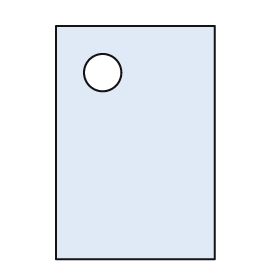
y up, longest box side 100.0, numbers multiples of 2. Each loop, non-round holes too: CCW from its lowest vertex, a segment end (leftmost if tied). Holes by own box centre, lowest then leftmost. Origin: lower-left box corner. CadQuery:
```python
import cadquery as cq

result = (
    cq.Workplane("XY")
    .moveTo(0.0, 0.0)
    .lineTo(68.0, 0.0)
    .lineTo(68.0, 100.0)
    .lineTo(0.0, 100.0)
    .close()
    .moveTo(20.0, 80.0)
    .circle(8.0)
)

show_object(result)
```